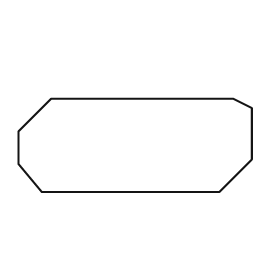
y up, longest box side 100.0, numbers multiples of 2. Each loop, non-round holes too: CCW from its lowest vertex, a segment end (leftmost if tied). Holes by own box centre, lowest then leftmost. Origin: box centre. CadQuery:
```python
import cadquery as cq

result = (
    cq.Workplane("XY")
    .moveTo(-40.0, -20.0)
    .lineTo(36.0, -20.0)
    .lineTo(50.0, -6.0)
    .lineTo(50.0, 16.0)
    .lineTo(42.0, 20.0)
    .lineTo(-36.0, 20.0)
    .lineTo(-50.0, 6.0)
    .lineTo(-50.0, -8.0)
    .close()
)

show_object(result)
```